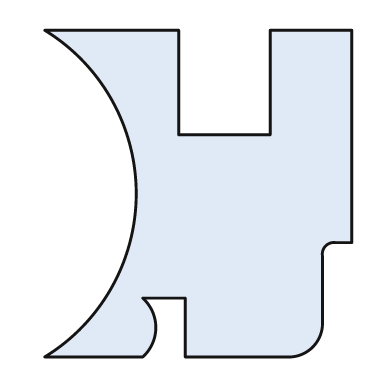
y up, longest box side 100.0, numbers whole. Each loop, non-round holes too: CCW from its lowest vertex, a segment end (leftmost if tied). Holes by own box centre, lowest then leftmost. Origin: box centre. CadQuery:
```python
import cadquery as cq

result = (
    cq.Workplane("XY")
    .moveTo(-47.0, -50.0)
    .lineTo(-17.0, -50.0)
    .threePointArc((-13.0, -41.0), (-17.0, -32.0))
    .lineTo(-4.0, -32.0)
    .lineTo(-4.0, -50.0)
    .lineTo(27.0, -50.0)
    .threePointArc((35.0, -47.0), (38.0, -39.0))
    .lineTo(38.0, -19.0)
    .threePointArc((39.0, -16.0), (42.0, -15.0))
    .lineTo(47.0, -15.0)
    .lineTo(47.0, 50.0)
    .lineTo(22.0, 50.0)
    .lineTo(22.0, 18.0)
    .lineTo(-6.0, 18.0)
    .lineTo(-6.0, 50.0)
    .lineTo(-47.0, 50.0)
    .threePointArc((-19.0, 0.0), (-47.0, -50.0))
    .close()
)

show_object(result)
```